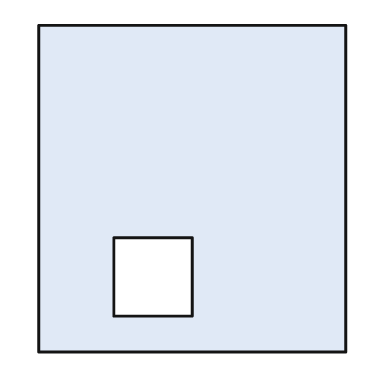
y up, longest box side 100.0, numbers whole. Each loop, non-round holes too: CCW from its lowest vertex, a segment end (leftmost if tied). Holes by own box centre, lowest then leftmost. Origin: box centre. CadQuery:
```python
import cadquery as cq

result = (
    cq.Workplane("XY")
    .moveTo(-47.0, -50.0)
    .lineTo(47.0, -50.0)
    .lineTo(47.0, 50.0)
    .lineTo(-47.0, 50.0)
    .close()
    .moveTo(-24.0, -39.0)
    .lineTo(0.0, -39.0)
    .lineTo(0.0, -15.0)
    .lineTo(-24.0, -15.0)
    .close()
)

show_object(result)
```